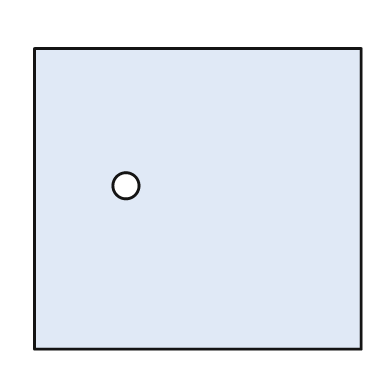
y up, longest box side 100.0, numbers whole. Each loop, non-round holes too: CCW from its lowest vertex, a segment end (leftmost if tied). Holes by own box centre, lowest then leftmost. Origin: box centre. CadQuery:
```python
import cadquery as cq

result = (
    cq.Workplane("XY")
    .moveTo(-50.0, -46.0)
    .lineTo(50.0, -46.0)
    .lineTo(50.0, 46.0)
    .lineTo(-50.0, 46.0)
    .close()
    .moveTo(-22.0, 4.0)
    .circle(4.0)
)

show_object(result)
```